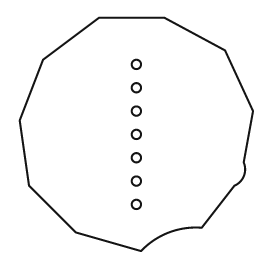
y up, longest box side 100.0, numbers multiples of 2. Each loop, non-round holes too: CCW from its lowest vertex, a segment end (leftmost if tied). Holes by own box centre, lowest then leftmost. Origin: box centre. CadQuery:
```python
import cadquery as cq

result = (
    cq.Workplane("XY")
    .moveTo(2.0, -50.0)
    .threePointArc((14.0, -42.0), (28.0, -40.0))
    .lineTo(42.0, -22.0)
    .threePointArc((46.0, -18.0), (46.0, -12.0))
    .lineTo(50.0, 10.0)
    .lineTo(38.0, 36.0)
    .lineTo(12.0, 50.0)
    .lineTo(-16.0, 50.0)
    .lineTo(-40.0, 32.0)
    .lineTo(-50.0, 6.0)
    .lineTo(-46.0, -22.0)
    .lineTo(-26.0, -42.0)
    .close()
    .moveTo(0.0, -30.0)
    .circle(2.0)
    .moveTo(0.0, -20.0)
    .circle(2.0)
    .moveTo(0.0, -10.0)
    .circle(2.0)
    .moveTo(0.0, 0.0)
    .circle(2.0)
    .moveTo(0.0, 10.0)
    .circle(2.0)
    .moveTo(0.0, 20.0)
    .circle(2.0)
    .moveTo(0.0, 30.0)
    .circle(2.0)
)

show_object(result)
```